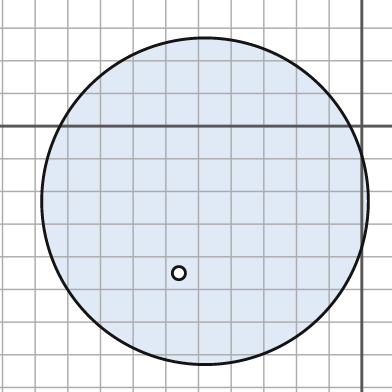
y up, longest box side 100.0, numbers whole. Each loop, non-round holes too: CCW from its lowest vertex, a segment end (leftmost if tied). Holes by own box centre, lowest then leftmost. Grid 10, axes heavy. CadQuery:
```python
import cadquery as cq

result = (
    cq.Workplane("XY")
    .moveTo(-48.0, -23.0)
    .circle(50.0)
    .moveTo(-56.0, -45.0)
    .circle(2.0)
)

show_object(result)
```